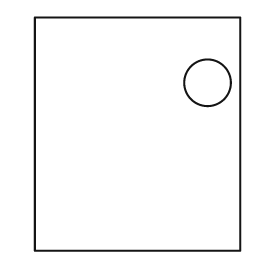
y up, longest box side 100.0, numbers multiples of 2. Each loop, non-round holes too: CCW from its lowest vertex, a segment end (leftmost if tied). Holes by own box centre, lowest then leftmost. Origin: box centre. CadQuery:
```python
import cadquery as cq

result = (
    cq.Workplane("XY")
    .moveTo(-44.0, -50.0)
    .lineTo(44.0, -50.0)
    .lineTo(44.0, 50.0)
    .lineTo(-44.0, 50.0)
    .close()
    .moveTo(30.0, 22.0)
    .circle(10.0)
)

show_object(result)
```